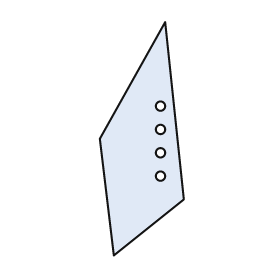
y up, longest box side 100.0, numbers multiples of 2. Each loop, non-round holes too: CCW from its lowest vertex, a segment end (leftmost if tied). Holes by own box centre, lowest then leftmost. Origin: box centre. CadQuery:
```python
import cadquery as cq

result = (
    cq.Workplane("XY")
    .moveTo(-12.0, -50.0)
    .lineTo(18.0, -26.0)
    .lineTo(10.0, 50.0)
    .lineTo(-18.0, 0.0)
    .close()
    .moveTo(8.0, -16.0)
    .circle(2.0)
    .moveTo(8.0, -6.0)
    .circle(2.0)
    .moveTo(8.0, 4.0)
    .circle(2.0)
    .moveTo(8.0, 14.0)
    .circle(2.0)
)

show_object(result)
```